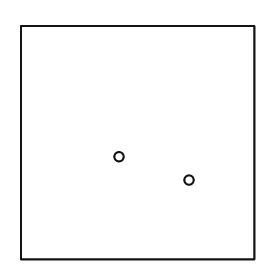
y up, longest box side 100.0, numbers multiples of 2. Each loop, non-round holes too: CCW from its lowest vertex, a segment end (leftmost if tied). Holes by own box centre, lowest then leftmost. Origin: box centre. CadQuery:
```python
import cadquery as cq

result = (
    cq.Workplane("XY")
    .moveTo(-50.0, -50.0)
    .lineTo(50.0, -50.0)
    .lineTo(50.0, 50.0)
    .lineTo(-50.0, 50.0)
    .close()
    .moveTo(22.0, -16.0)
    .circle(2.0)
    .moveTo(-8.0, -6.0)
    .circle(2.0)
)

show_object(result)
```